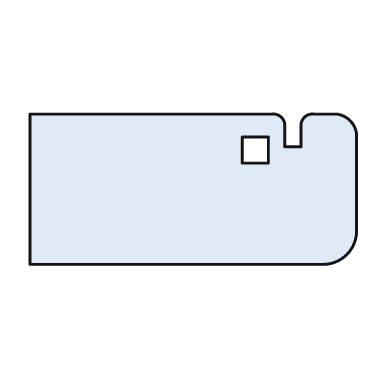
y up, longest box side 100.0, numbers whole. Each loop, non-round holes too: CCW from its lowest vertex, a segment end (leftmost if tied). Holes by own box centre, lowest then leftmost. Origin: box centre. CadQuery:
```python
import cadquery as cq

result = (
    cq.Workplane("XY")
    .moveTo(-50.0, -23.0)
    .lineTo(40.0, -23.0)
    .threePointArc((47.0, -20.0), (50.0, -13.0))
    .lineTo(50.0, 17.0)
    .threePointArc((48.0, 21.0), (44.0, 23.0))
    .lineTo(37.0, 23.0)
    .threePointArc((34.0, 22.0), (33.0, 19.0))
    .lineTo(33.0, 13.0)
    .lineTo(28.0, 13.0)
    .lineTo(28.0, 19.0)
    .threePointArc((27.0, 22.0), (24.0, 23.0))
    .lineTo(-50.0, 23.0)
    .close()
    .moveTo(15.0, 8.0)
    .lineTo(23.0, 8.0)
    .lineTo(23.0, 16.0)
    .lineTo(15.0, 16.0)
    .close()
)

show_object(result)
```